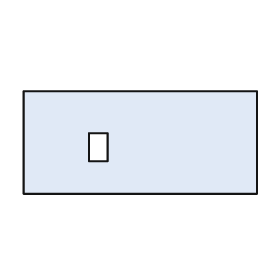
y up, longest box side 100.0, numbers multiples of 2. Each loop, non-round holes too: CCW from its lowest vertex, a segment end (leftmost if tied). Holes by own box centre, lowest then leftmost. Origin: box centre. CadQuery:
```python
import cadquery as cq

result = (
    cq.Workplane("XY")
    .moveTo(-50.0, -22.0)
    .lineTo(50.0, -22.0)
    .lineTo(50.0, 22.0)
    .lineTo(-50.0, 22.0)
    .close()
    .moveTo(-22.0, -8.0)
    .lineTo(-14.0, -8.0)
    .lineTo(-14.0, 4.0)
    .lineTo(-22.0, 4.0)
    .close()
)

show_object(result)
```